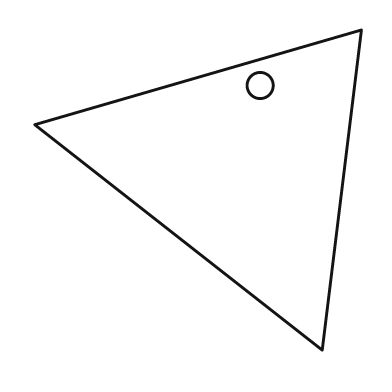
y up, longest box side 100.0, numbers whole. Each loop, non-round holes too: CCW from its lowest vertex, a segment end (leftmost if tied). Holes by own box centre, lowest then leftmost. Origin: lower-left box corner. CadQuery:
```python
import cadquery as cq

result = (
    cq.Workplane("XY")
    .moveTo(88.0, 0.0)
    .lineTo(100.0, 98.0)
    .lineTo(0.0, 69.0)
    .close()
    .moveTo(69.0, 81.0)
    .circle(4.0)
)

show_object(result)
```